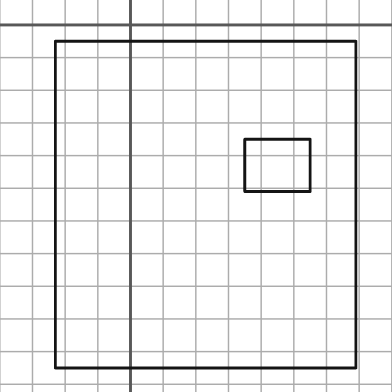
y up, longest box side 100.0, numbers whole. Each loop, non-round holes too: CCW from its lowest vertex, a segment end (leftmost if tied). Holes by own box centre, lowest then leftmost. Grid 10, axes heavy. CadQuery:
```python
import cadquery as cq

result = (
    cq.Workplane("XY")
    .moveTo(-23.0, -105.0)
    .lineTo(69.0, -105.0)
    .lineTo(69.0, -5.0)
    .lineTo(-23.0, -5.0)
    .close()
    .moveTo(35.0, -51.0)
    .lineTo(55.0, -51.0)
    .lineTo(55.0, -35.0)
    .lineTo(35.0, -35.0)
    .close()
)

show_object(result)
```